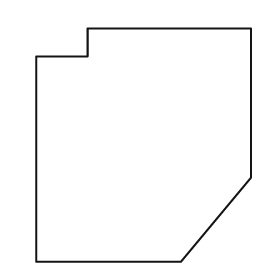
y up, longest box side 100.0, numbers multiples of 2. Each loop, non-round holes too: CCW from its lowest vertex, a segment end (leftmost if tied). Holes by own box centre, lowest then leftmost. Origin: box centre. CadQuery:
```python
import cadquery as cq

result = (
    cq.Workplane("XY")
    .moveTo(-46.0, -50.0)
    .lineTo(16.0, -50.0)
    .lineTo(46.0, -14.0)
    .lineTo(46.0, 50.0)
    .lineTo(-24.0, 50.0)
    .lineTo(-24.0, 38.0)
    .lineTo(-46.0, 38.0)
    .close()
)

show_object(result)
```